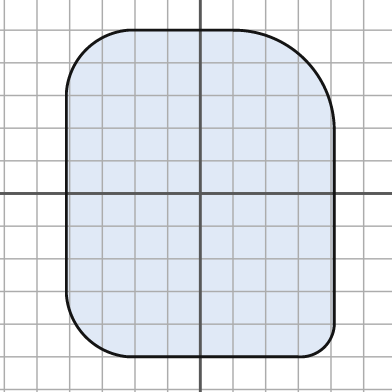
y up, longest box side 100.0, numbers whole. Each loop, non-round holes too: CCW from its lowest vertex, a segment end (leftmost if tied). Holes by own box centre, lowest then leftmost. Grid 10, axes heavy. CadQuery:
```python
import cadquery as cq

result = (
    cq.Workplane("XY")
    .moveTo(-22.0, -50.0)
    .lineTo(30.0, -50.0)
    .threePointArc((38.0, -47.0), (41.0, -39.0))
    .lineTo(41.0, 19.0)
    .threePointArc((32.0, 41.0), (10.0, 50.0))
    .lineTo(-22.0, 50.0)
    .threePointArc((-35.0, 44.0), (-41.0, 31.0))
    .lineTo(-41.0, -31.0)
    .threePointArc((-35.0, -44.0), (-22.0, -50.0))
    .close()
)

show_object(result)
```